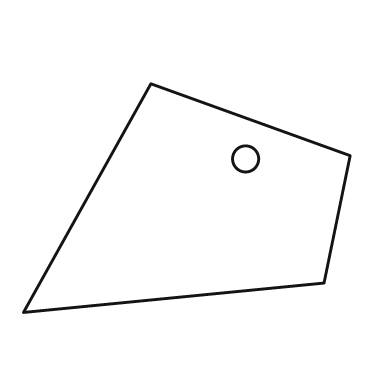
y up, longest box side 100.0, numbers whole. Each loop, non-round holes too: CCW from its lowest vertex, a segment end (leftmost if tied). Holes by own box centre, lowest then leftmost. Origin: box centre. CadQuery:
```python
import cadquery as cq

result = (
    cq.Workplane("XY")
    .moveTo(-50.0, -35.0)
    .lineTo(42.0, -26.0)
    .lineTo(50.0, 13.0)
    .lineTo(-11.0, 35.0)
    .close()
    .moveTo(18.0, 12.0)
    .circle(4.0)
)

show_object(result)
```